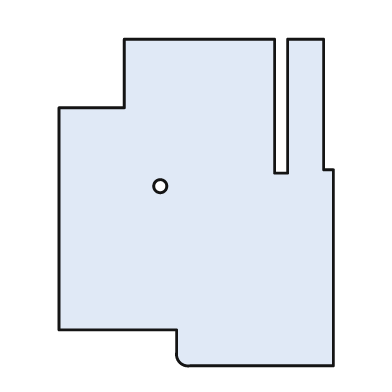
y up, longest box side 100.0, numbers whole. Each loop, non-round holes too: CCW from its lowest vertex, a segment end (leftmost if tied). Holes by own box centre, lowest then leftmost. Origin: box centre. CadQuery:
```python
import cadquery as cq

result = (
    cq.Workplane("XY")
    .moveTo(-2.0, -50.0)
    .lineTo(42.0, -50.0)
    .lineTo(42.0, 10.0)
    .lineTo(39.0, 10.0)
    .lineTo(39.0, 50.0)
    .lineTo(28.0, 50.0)
    .lineTo(28.0, 9.0)
    .lineTo(24.0, 9.0)
    .lineTo(24.0, 50.0)
    .lineTo(-22.0, 50.0)
    .lineTo(-22.0, 29.0)
    .lineTo(-42.0, 29.0)
    .lineTo(-42.0, -39.0)
    .lineTo(-6.0, -39.0)
    .lineTo(-6.0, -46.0)
    .threePointArc((-5.0, -49.0), (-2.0, -50.0))
    .close()
    .moveTo(-11.0, 5.0)
    .circle(2.0)
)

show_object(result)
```